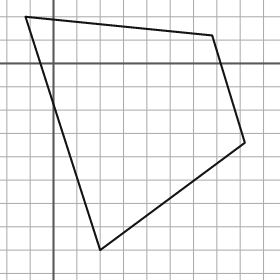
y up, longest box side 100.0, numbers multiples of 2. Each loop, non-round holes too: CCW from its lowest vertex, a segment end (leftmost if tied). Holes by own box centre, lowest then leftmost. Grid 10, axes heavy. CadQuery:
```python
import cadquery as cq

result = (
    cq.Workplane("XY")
    .moveTo(20.0, -80.0)
    .lineTo(82.0, -34.0)
    .lineTo(68.0, 12.0)
    .lineTo(-12.0, 20.0)
    .close()
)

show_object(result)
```